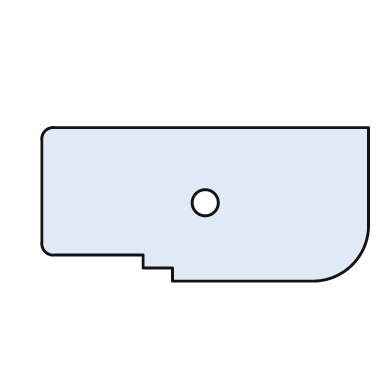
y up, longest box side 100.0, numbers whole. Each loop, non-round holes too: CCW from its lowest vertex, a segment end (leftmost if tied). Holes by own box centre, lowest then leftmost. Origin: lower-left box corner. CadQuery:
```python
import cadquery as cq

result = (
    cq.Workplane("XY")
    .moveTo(40.0, 0.0)
    .lineTo(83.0, 0.0)
    .threePointArc((95.0, 5.0), (100.0, 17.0))
    .lineTo(100.0, 47.0)
    .lineTo(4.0, 47.0)
    .threePointArc((1.0, 46.0), (0.0, 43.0))
    .lineTo(0.0, 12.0)
    .threePointArc((1.0, 9.0), (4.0, 8.0))
    .lineTo(31.0, 8.0)
    .lineTo(31.0, 4.0)
    .lineTo(40.0, 4.0)
    .close()
    .moveTo(50.0, 24.0)
    .circle(4.0)
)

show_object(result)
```